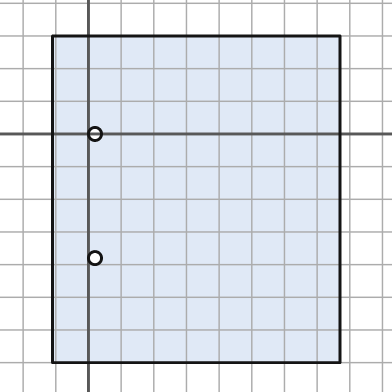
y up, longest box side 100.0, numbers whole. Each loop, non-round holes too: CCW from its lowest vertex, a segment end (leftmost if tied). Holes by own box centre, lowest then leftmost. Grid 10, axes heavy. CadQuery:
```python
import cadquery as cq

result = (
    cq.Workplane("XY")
    .moveTo(-11.0, -70.0)
    .lineTo(77.0, -70.0)
    .lineTo(77.0, 30.0)
    .lineTo(-11.0, 30.0)
    .close()
    .moveTo(2.0, -38.0)
    .circle(2.0)
    .moveTo(2.0, 0.0)
    .circle(2.0)
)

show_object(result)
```